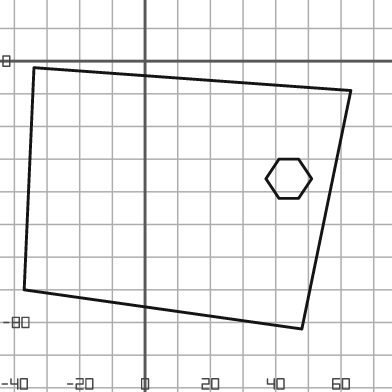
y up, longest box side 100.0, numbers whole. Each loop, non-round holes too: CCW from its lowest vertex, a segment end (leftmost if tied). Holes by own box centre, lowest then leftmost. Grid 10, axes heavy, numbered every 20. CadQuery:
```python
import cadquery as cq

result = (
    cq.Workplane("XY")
    .moveTo(48.0, -82.0)
    .lineTo(63.0, -9.0)
    .lineTo(-34.0, -2.0)
    .lineTo(-37.0, -70.0)
    .close()
    .moveTo(41.0, -42.0)
    .lineTo(47.0, -42.0)
    .lineTo(51.0, -36.0)
    .lineTo(47.0, -30.0)
    .lineTo(41.0, -30.0)
    .lineTo(37.0, -36.0)
    .close()
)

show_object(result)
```